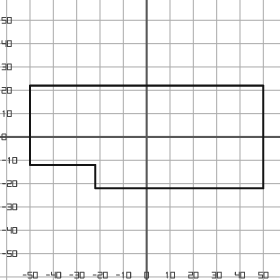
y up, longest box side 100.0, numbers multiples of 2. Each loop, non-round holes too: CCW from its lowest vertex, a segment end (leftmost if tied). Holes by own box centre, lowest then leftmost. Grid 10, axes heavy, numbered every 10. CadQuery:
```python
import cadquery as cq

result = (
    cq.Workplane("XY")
    .moveTo(-22.0, -22.0)
    .lineTo(50.0, -22.0)
    .lineTo(50.0, 22.0)
    .lineTo(-50.0, 22.0)
    .lineTo(-50.0, -12.0)
    .lineTo(-22.0, -12.0)
    .close()
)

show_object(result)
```